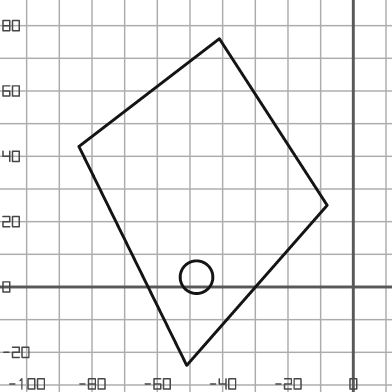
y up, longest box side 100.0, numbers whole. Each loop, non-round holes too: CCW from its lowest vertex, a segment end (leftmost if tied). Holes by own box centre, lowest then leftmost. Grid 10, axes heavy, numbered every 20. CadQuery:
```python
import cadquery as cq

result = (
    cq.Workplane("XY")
    .moveTo(-51.0, -24.0)
    .lineTo(-8.0, 25.0)
    .lineTo(-41.0, 76.0)
    .lineTo(-84.0, 43.0)
    .close()
    .moveTo(-48.0, 3.0)
    .circle(5.0)
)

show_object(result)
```